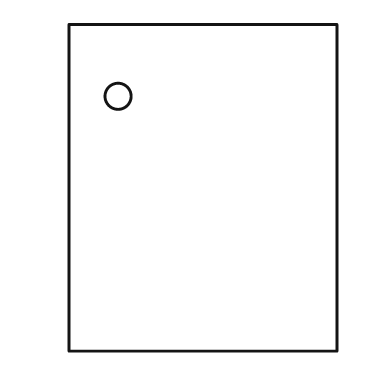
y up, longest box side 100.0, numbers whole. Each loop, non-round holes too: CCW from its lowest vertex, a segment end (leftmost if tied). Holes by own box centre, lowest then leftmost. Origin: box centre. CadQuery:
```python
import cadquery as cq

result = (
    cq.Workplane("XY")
    .moveTo(-41.0, -50.0)
    .lineTo(41.0, -50.0)
    .lineTo(41.0, 50.0)
    .lineTo(-41.0, 50.0)
    .close()
    .moveTo(-26.0, 28.0)
    .circle(4.0)
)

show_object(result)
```